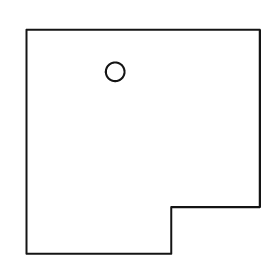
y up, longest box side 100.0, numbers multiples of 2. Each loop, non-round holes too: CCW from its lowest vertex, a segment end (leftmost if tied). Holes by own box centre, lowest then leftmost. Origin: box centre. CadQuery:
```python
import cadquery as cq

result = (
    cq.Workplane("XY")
    .moveTo(-50.0, -48.0)
    .lineTo(12.0, -48.0)
    .lineTo(12.0, -28.0)
    .lineTo(50.0, -28.0)
    .lineTo(50.0, 48.0)
    .lineTo(-50.0, 48.0)
    .close()
    .moveTo(-12.0, 30.0)
    .circle(4.0)
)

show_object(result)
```